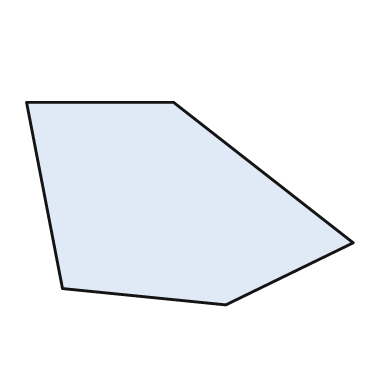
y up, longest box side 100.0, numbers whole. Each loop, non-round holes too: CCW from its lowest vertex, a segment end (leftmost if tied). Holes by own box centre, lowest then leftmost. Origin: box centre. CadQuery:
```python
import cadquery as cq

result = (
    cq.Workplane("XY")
    .moveTo(11.0, -31.0)
    .lineTo(50.0, -12.0)
    .lineTo(-5.0, 31.0)
    .lineTo(-50.0, 31.0)
    .lineTo(-39.0, -26.0)
    .close()
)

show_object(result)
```